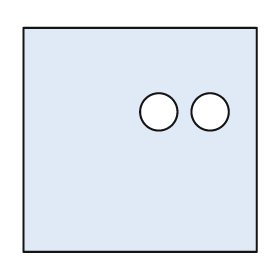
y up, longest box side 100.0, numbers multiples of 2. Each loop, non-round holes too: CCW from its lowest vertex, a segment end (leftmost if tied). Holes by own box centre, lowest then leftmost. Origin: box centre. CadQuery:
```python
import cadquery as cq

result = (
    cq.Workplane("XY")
    .moveTo(-50.0, -48.0)
    .lineTo(50.0, -48.0)
    .lineTo(50.0, 48.0)
    .lineTo(-50.0, 48.0)
    .close()
    .moveTo(8.0, 12.0)
    .circle(8.0)
    .moveTo(30.0, 12.0)
    .circle(8.0)
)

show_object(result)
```